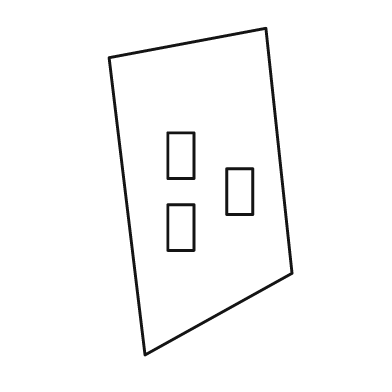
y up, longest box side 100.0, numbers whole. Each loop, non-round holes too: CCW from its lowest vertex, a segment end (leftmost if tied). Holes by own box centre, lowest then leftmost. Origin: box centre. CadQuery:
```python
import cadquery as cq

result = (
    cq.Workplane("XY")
    .moveTo(-17.0, -50.0)
    .lineTo(28.0, -25.0)
    .lineTo(20.0, 50.0)
    .lineTo(-28.0, 41.0)
    .close()
    .moveTo(-10.0, -18.0)
    .lineTo(-2.0, -18.0)
    .lineTo(-2.0, -4.0)
    .lineTo(-10.0, -4.0)
    .close()
    .moveTo(8.0, -7.0)
    .lineTo(16.0, -7.0)
    .lineTo(16.0, 7.0)
    .lineTo(8.0, 7.0)
    .close()
    .moveTo(-10.0, 4.0)
    .lineTo(-2.0, 4.0)
    .lineTo(-2.0, 18.0)
    .lineTo(-10.0, 18.0)
    .close()
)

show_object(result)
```